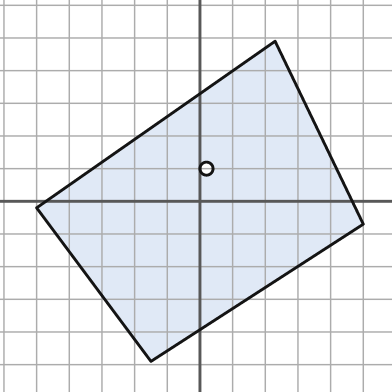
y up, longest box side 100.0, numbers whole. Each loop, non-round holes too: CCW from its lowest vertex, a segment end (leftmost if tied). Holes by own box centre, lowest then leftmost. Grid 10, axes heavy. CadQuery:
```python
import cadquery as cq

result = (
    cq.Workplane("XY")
    .moveTo(-15.0, -49.0)
    .lineTo(50.0, -7.0)
    .lineTo(23.0, 49.0)
    .lineTo(-50.0, -2.0)
    .close()
    .moveTo(2.0, 10.0)
    .circle(2.0)
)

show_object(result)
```